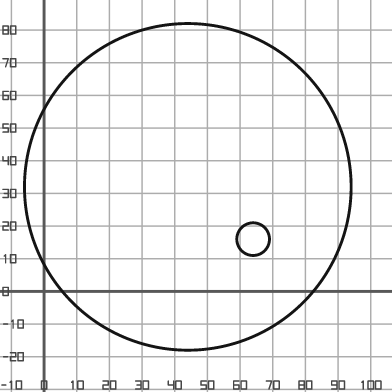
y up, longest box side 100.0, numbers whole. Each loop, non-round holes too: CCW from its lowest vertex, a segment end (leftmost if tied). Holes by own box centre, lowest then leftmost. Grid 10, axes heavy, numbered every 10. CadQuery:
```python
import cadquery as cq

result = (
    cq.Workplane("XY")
    .moveTo(44.0, 32.0)
    .circle(50.0)
    .moveTo(64.0, 16.0)
    .circle(5.0)
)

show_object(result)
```